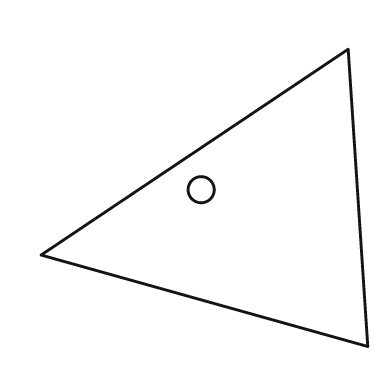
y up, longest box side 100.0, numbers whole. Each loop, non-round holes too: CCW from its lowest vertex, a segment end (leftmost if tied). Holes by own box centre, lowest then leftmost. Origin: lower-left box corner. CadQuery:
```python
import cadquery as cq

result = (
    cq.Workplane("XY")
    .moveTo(100.0, 0.0)
    .lineTo(94.0, 91.0)
    .lineTo(0.0, 28.0)
    .close()
    .moveTo(49.0, 48.0)
    .circle(4.0)
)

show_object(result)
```